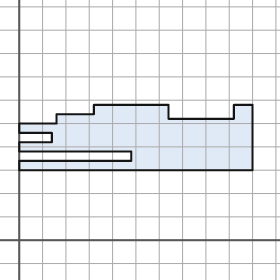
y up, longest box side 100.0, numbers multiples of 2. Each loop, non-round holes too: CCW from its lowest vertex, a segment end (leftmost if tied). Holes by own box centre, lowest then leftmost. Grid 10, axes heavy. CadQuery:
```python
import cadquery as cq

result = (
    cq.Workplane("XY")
    .moveTo(0.0, 30.0)
    .lineTo(100.0, 30.0)
    .lineTo(100.0, 58.0)
    .lineTo(92.0, 58.0)
    .lineTo(92.0, 52.0)
    .lineTo(64.0, 52.0)
    .lineTo(64.0, 58.0)
    .lineTo(32.0, 58.0)
    .lineTo(32.0, 54.0)
    .lineTo(16.0, 54.0)
    .lineTo(16.0, 50.0)
    .lineTo(0.0, 50.0)
    .lineTo(0.0, 46.0)
    .lineTo(14.0, 46.0)
    .lineTo(14.0, 42.0)
    .lineTo(0.0, 42.0)
    .lineTo(0.0, 38.0)
    .lineTo(48.0, 38.0)
    .lineTo(48.0, 34.0)
    .lineTo(0.0, 34.0)
    .close()
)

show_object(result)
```